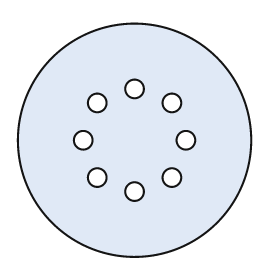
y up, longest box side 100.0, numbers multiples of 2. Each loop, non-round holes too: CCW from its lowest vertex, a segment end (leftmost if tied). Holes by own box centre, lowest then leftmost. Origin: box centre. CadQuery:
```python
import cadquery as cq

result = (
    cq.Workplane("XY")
    .moveTo(0.0, 0.0)
    .circle(50.0)
    .moveTo(0.0, -22.0)
    .circle(4.0)
    .moveTo(-16.0, -16.0)
    .circle(4.0)
    .moveTo(16.0, -16.0)
    .circle(4.0)
    .moveTo(-22.0, 0.0)
    .circle(4.0)
    .moveTo(22.0, 0.0)
    .circle(4.0)
    .moveTo(-16.0, 16.0)
    .circle(4.0)
    .moveTo(16.0, 16.0)
    .circle(4.0)
    .moveTo(0.0, 22.0)
    .circle(4.0)
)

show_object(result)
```